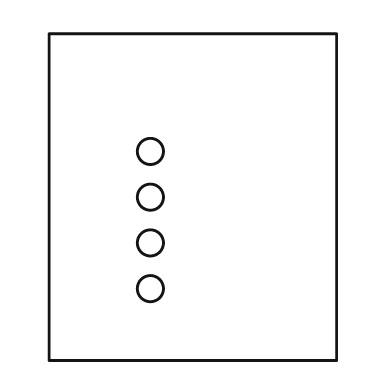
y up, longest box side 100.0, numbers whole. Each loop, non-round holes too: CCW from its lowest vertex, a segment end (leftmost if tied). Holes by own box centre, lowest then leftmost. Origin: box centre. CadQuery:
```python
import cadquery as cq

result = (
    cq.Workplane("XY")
    .moveTo(-44.0, -50.0)
    .lineTo(44.0, -50.0)
    .lineTo(44.0, 50.0)
    .lineTo(-44.0, 50.0)
    .close()
    .moveTo(-13.0, -28.0)
    .circle(4.0)
    .moveTo(-13.0, -14.0)
    .circle(4.0)
    .moveTo(-13.0, 0.0)
    .circle(4.0)
    .moveTo(-13.0, 14.0)
    .circle(4.0)
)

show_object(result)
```